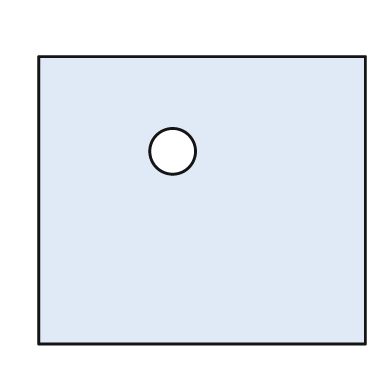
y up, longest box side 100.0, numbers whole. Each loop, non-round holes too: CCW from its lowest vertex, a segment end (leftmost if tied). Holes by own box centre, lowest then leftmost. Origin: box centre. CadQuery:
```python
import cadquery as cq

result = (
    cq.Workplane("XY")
    .moveTo(-50.0, -44.0)
    .lineTo(50.0, -44.0)
    .lineTo(50.0, 44.0)
    .lineTo(-50.0, 44.0)
    .close()
    .moveTo(-9.0, 15.0)
    .circle(7.0)
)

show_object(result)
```